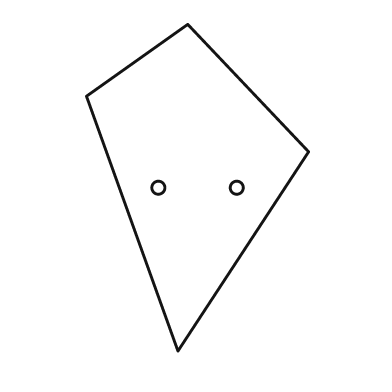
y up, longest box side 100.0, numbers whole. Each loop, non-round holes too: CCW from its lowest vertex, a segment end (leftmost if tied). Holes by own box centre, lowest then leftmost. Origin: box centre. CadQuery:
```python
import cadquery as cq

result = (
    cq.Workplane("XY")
    .moveTo(-6.0, -50.0)
    .lineTo(34.0, 11.0)
    .lineTo(-3.0, 50.0)
    .lineTo(-34.0, 28.0)
    .close()
    .moveTo(-12.0, 0.0)
    .circle(2.0)
    .moveTo(12.0, 0.0)
    .circle(2.0)
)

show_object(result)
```